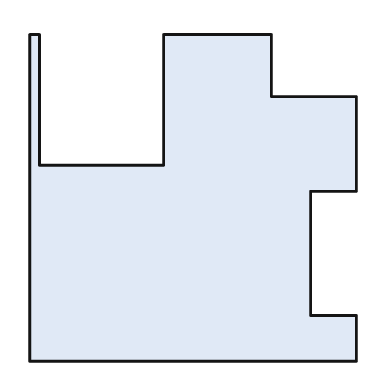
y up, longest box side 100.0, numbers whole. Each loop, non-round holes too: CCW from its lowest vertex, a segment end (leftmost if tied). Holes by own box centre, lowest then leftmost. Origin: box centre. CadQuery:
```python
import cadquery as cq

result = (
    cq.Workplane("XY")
    .moveTo(-50.0, -50.0)
    .lineTo(50.0, -50.0)
    .lineTo(50.0, -36.0)
    .lineTo(36.0, -36.0)
    .lineTo(36.0, 2.0)
    .lineTo(50.0, 2.0)
    .lineTo(50.0, 31.0)
    .lineTo(24.0, 31.0)
    .lineTo(24.0, 50.0)
    .lineTo(-9.0, 50.0)
    .lineTo(-9.0, 10.0)
    .lineTo(-47.0, 10.0)
    .lineTo(-47.0, 50.0)
    .lineTo(-50.0, 50.0)
    .close()
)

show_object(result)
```